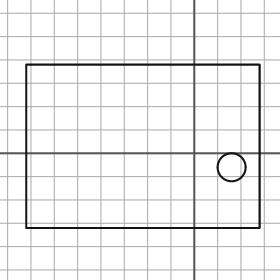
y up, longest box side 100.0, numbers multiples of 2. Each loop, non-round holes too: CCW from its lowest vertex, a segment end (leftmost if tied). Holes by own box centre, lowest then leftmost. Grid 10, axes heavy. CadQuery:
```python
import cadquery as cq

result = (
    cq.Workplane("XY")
    .moveTo(-72.0, -32.0)
    .lineTo(28.0, -32.0)
    .lineTo(28.0, 38.0)
    .lineTo(-72.0, 38.0)
    .close()
    .moveTo(16.0, -6.0)
    .circle(6.0)
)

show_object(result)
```